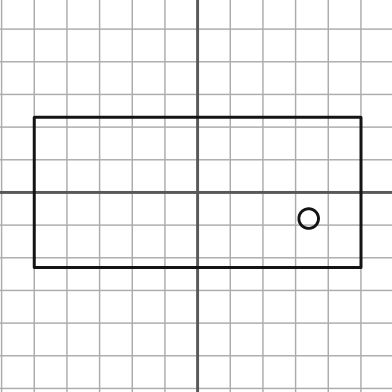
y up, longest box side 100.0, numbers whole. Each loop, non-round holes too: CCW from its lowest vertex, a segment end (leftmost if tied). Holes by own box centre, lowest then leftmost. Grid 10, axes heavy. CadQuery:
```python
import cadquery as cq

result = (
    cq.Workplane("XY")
    .moveTo(-50.0, -23.0)
    .lineTo(50.0, -23.0)
    .lineTo(50.0, 23.0)
    .lineTo(-50.0, 23.0)
    .close()
    .moveTo(34.0, -8.0)
    .circle(3.0)
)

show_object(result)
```